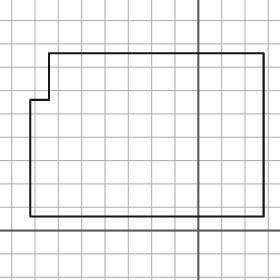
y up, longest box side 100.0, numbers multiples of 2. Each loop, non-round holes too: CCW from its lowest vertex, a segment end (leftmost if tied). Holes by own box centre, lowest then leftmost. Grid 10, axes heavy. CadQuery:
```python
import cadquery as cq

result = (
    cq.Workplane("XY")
    .moveTo(-72.0, 6.0)
    .lineTo(28.0, 6.0)
    .lineTo(28.0, 76.0)
    .lineTo(-64.0, 76.0)
    .lineTo(-64.0, 56.0)
    .lineTo(-72.0, 56.0)
    .close()
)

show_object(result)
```